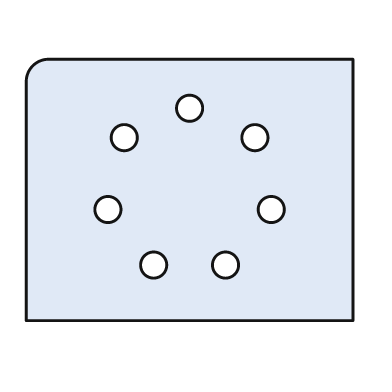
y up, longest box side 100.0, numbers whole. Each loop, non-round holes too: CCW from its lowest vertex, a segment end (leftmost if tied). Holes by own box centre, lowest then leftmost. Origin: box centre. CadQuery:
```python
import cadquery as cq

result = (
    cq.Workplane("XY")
    .moveTo(-50.0, -40.0)
    .lineTo(50.0, -40.0)
    .lineTo(50.0, 40.0)
    .lineTo(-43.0, 40.0)
    .threePointArc((-48.0, 38.0), (-50.0, 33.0))
    .close()
    .moveTo(-11.0, -23.0)
    .circle(4.0)
    .moveTo(11.0, -23.0)
    .circle(4.0)
    .moveTo(-25.0, -6.0)
    .circle(4.0)
    .moveTo(25.0, -6.0)
    .circle(4.0)
    .moveTo(-20.0, 16.0)
    .circle(4.0)
    .moveTo(20.0, 16.0)
    .circle(4.0)
    .moveTo(0.0, 25.0)
    .circle(4.0)
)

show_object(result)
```